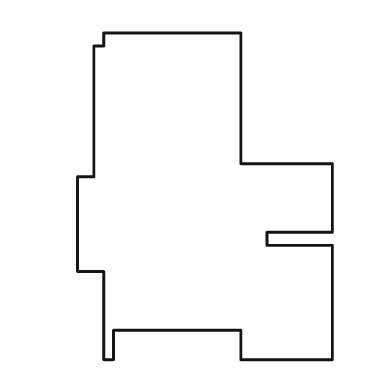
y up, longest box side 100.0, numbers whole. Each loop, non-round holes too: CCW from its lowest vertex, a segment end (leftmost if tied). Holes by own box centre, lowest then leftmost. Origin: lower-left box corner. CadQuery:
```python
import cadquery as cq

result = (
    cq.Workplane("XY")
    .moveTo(8.0, 0.0)
    .lineTo(11.0, 0.0)
    .lineTo(11.0, 9.0)
    .lineTo(50.0, 9.0)
    .lineTo(50.0, 0.0)
    .lineTo(78.0, 0.0)
    .lineTo(78.0, 35.0)
    .lineTo(58.0, 35.0)
    .lineTo(58.0, 39.0)
    .lineTo(78.0, 39.0)
    .lineTo(78.0, 60.0)
    .lineTo(50.0, 60.0)
    .lineTo(50.0, 100.0)
    .lineTo(8.0, 100.0)
    .lineTo(8.0, 96.0)
    .lineTo(5.0, 96.0)
    .lineTo(5.0, 56.0)
    .lineTo(0.0, 56.0)
    .lineTo(0.0, 27.0)
    .lineTo(8.0, 27.0)
    .close()
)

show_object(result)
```